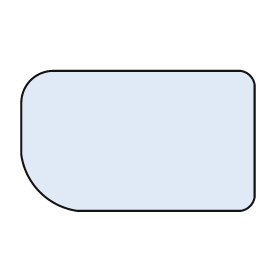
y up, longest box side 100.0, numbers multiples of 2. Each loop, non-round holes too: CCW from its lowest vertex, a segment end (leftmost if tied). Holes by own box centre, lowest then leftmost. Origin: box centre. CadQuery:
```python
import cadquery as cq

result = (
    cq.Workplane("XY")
    .moveTo(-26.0, -30.0)
    .lineTo(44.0, -30.0)
    .threePointArc((48.0, -28.0), (50.0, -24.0))
    .lineTo(50.0, 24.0)
    .threePointArc((48.0, 28.0), (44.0, 30.0))
    .lineTo(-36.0, 30.0)
    .threePointArc((-46.0, 26.0), (-50.0, 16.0))
    .lineTo(-50.0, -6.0)
    .threePointArc((-42.0, -22.0), (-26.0, -30.0))
    .close()
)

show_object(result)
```